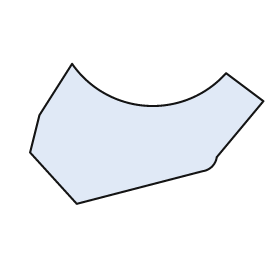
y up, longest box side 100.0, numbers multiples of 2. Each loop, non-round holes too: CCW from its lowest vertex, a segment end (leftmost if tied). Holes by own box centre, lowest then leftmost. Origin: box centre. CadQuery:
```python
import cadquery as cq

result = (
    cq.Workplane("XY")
    .moveTo(-30.0, -30.0)
    .lineTo(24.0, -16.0)
    .threePointArc((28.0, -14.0), (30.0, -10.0))
    .lineTo(50.0, 14.0)
    .lineTo(34.0, 26.0)
    .threePointArc((0.0, 12.0), (-32.0, 30.0))
    .lineTo(-46.0, 8.0)
    .lineTo(-50.0, -8.0)
    .close()
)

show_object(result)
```